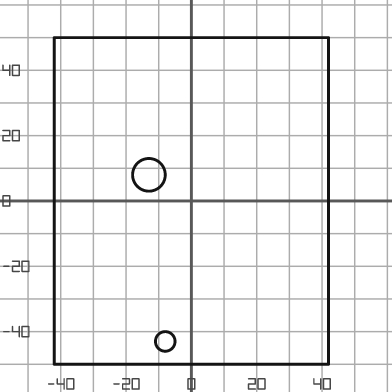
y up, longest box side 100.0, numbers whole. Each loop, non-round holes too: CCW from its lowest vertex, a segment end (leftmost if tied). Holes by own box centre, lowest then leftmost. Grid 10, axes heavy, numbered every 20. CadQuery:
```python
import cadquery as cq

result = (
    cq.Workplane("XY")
    .moveTo(-42.0, -50.0)
    .lineTo(42.0, -50.0)
    .lineTo(42.0, 50.0)
    .lineTo(-42.0, 50.0)
    .close()
    .moveTo(-8.0, -43.0)
    .circle(3.0)
    .moveTo(-13.0, 8.0)
    .circle(5.0)
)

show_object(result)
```